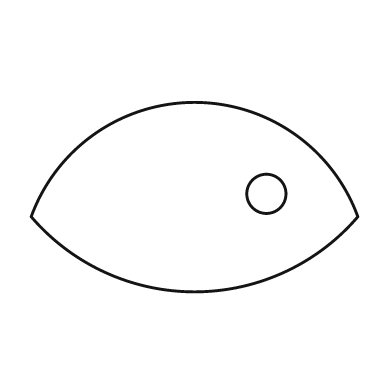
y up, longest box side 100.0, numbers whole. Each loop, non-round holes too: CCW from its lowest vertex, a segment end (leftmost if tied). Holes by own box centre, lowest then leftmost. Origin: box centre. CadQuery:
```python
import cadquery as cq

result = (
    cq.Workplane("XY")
    .moveTo(-50.0, -6.0)
    .threePointArc((0.0, -29.0), (50.0, -6.0))
    .threePointArc((0.0, 29.0), (-50.0, -6.0))
    .close()
    .moveTo(22.0, 1.0)
    .circle(6.0)
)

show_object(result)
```